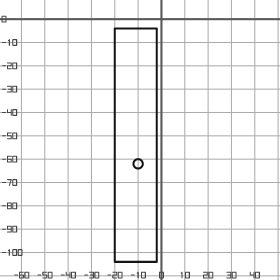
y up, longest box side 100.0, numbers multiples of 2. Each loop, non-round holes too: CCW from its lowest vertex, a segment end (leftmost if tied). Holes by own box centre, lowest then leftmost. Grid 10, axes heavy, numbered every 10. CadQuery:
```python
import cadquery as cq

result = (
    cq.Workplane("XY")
    .moveTo(-20.0, -104.0)
    .lineTo(-2.0, -104.0)
    .lineTo(-2.0, -4.0)
    .lineTo(-20.0, -4.0)
    .close()
    .moveTo(-10.0, -62.0)
    .circle(2.0)
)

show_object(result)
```